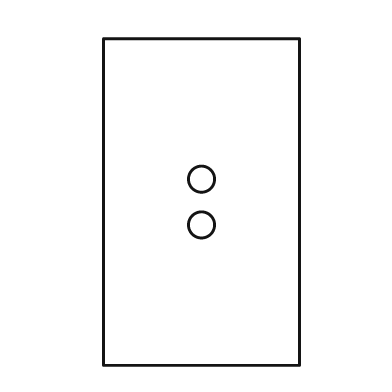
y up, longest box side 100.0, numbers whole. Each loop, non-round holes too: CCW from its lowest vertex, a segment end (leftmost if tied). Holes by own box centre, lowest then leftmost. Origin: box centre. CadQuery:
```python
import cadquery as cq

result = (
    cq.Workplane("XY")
    .moveTo(-30.0, -50.0)
    .lineTo(30.0, -50.0)
    .lineTo(30.0, 50.0)
    .lineTo(-30.0, 50.0)
    .close()
    .moveTo(0.0, -7.0)
    .circle(4.0)
    .moveTo(0.0, 7.0)
    .circle(4.0)
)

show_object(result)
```